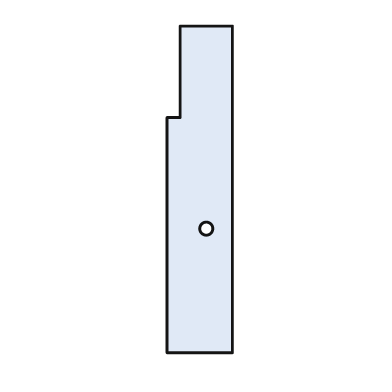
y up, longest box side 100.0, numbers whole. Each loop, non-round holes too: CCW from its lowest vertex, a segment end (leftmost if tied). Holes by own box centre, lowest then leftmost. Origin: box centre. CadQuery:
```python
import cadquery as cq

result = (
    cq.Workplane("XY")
    .moveTo(-10.0, -50.0)
    .lineTo(10.0, -50.0)
    .lineTo(10.0, 50.0)
    .lineTo(-6.0, 50.0)
    .lineTo(-6.0, 22.0)
    .lineTo(-10.0, 22.0)
    .close()
    .moveTo(2.0, -12.0)
    .circle(2.0)
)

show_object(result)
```